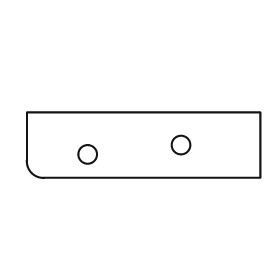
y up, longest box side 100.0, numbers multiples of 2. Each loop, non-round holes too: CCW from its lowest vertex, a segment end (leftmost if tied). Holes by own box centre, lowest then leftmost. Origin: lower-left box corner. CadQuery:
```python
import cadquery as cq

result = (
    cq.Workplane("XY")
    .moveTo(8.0, 0.0)
    .lineTo(100.0, 0.0)
    .lineTo(100.0, 28.0)
    .lineTo(0.0, 28.0)
    .lineTo(0.0, 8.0)
    .threePointArc((2.0, 2.0), (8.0, 0.0))
    .close()
    .moveTo(26.0, 10.0)
    .circle(4.0)
    .moveTo(66.0, 14.0)
    .circle(4.0)
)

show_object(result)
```